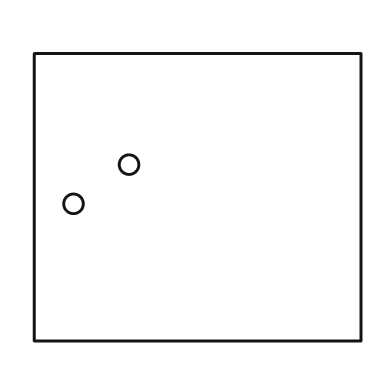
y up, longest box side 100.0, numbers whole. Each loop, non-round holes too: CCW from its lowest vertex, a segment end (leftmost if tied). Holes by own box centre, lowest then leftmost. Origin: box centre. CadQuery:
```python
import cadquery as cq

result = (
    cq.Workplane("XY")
    .moveTo(-50.0, -44.0)
    .lineTo(50.0, -44.0)
    .lineTo(50.0, 44.0)
    .lineTo(-50.0, 44.0)
    .close()
    .moveTo(-38.0, -2.0)
    .circle(3.0)
    .moveTo(-21.0, 10.0)
    .circle(3.0)
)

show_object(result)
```